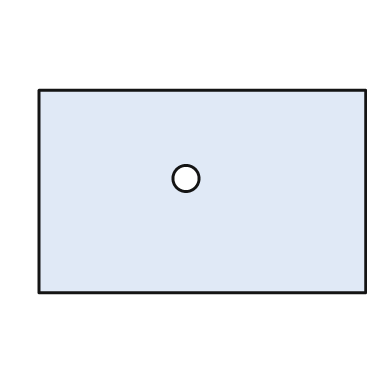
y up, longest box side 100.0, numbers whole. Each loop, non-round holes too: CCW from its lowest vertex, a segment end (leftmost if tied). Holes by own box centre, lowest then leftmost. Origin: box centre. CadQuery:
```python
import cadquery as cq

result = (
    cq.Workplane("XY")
    .moveTo(-50.0, -31.0)
    .lineTo(50.0, -31.0)
    .lineTo(50.0, 31.0)
    .lineTo(-50.0, 31.0)
    .close()
    .moveTo(-5.0, 4.0)
    .circle(4.0)
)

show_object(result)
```